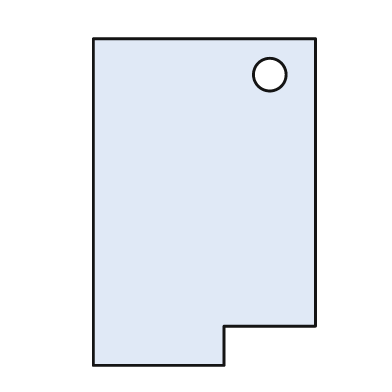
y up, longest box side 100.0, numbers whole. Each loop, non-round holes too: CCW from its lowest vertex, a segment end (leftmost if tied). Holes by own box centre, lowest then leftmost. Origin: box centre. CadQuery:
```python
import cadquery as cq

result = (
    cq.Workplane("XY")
    .moveTo(-34.0, -50.0)
    .lineTo(6.0, -50.0)
    .lineTo(6.0, -38.0)
    .lineTo(34.0, -38.0)
    .lineTo(34.0, 50.0)
    .lineTo(-34.0, 50.0)
    .close()
    .moveTo(20.0, 39.0)
    .circle(5.0)
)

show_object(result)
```